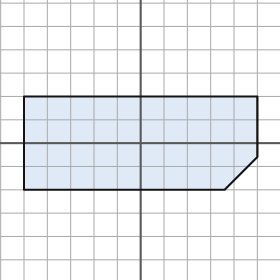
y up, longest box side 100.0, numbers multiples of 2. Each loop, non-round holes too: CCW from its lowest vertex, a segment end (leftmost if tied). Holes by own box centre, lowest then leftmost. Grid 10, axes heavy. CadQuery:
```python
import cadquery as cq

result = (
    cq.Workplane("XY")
    .moveTo(-50.0, -20.0)
    .lineTo(36.0, -20.0)
    .lineTo(50.0, -6.0)
    .lineTo(50.0, 20.0)
    .lineTo(-50.0, 20.0)
    .close()
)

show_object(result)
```